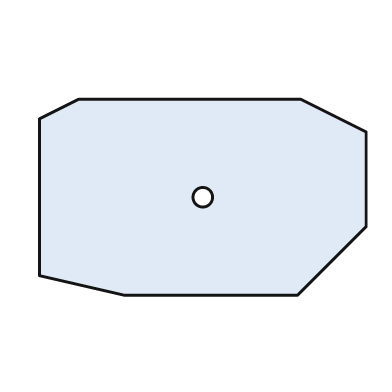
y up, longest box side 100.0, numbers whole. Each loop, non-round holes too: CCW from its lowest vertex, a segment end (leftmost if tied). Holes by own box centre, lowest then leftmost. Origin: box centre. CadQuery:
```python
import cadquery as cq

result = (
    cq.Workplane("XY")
    .moveTo(-24.0, -30.0)
    .lineTo(29.0, -30.0)
    .lineTo(50.0, -9.0)
    .lineTo(50.0, 20.0)
    .lineTo(30.0, 30.0)
    .lineTo(-38.0, 30.0)
    .lineTo(-50.0, 24.0)
    .lineTo(-50.0, -24.0)
    .close()
    .moveTo(0.0, 0.0)
    .circle(3.0)
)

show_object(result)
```